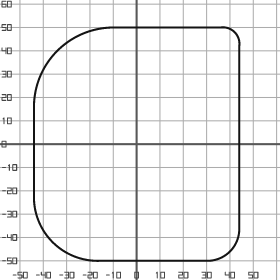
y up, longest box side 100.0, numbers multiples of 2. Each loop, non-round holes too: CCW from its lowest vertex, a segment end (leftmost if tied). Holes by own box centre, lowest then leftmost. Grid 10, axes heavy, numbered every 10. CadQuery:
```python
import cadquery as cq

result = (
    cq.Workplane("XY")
    .moveTo(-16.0, -50.0)
    .lineTo(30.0, -50.0)
    .threePointArc((40.0, -46.0), (44.0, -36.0))
    .lineTo(44.0, 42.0)
    .threePointArc((42.0, 48.0), (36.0, 50.0))
    .lineTo(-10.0, 50.0)
    .threePointArc((-34.0, 40.0), (-44.0, 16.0))
    .lineTo(-44.0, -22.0)
    .threePointArc((-36.0, -42.0), (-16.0, -50.0))
    .close()
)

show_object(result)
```